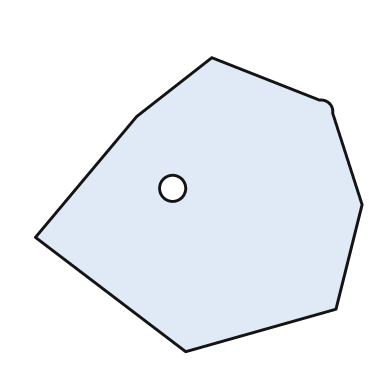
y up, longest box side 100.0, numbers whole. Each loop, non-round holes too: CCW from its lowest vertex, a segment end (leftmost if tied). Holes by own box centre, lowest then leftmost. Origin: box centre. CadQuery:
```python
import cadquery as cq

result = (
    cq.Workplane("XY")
    .moveTo(-4.0, -45.0)
    .lineTo(42.0, -32.0)
    .lineTo(50.0, 0.0)
    .lineTo(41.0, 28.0)
    .threePointArc((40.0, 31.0), (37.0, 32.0))
    .lineTo(4.0, 45.0)
    .lineTo(-19.0, 27.0)
    .lineTo(-50.0, -10.0)
    .close()
    .moveTo(-8.0, 5.0)
    .circle(4.0)
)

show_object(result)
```